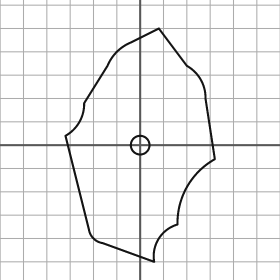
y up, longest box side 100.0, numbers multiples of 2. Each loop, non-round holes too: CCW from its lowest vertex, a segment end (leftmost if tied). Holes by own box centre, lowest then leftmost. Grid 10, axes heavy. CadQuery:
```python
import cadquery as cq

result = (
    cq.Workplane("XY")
    .moveTo(6.0, -50.0)
    .threePointArc((8.0, -40.0), (16.0, -34.0))
    .threePointArc((20.0, -18.0), (32.0, -6.0))
    .lineTo(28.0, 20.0)
    .threePointArc((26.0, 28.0), (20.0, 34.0))
    .lineTo(8.0, 50.0)
    .lineTo(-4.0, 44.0)
    .threePointArc((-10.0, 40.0), (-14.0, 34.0))
    .lineTo(-24.0, 18.0)
    .threePointArc((-26.0, 10.0), (-32.0, 4.0))
    .lineTo(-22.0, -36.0)
    .threePointArc((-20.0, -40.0), (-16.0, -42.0))
    .close()
    .moveTo(0.0, 0.0)
    .circle(4.0)
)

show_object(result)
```